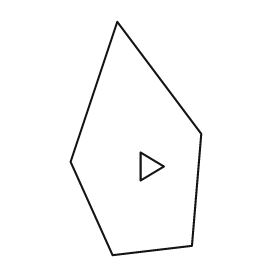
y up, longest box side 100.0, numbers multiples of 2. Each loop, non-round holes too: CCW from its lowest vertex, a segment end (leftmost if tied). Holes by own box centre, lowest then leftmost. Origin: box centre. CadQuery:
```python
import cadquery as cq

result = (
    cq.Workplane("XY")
    .moveTo(-10.0, -50.0)
    .lineTo(24.0, -46.0)
    .lineTo(28.0, 2.0)
    .lineTo(-8.0, 50.0)
    .lineTo(-28.0, -10.0)
    .close()
    .moveTo(2.0, -18.0)
    .lineTo(12.0, -12.0)
    .lineTo(2.0, -6.0)
    .close()
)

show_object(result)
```